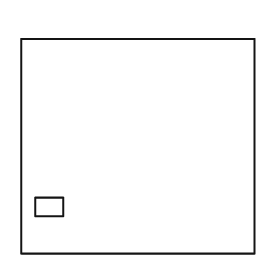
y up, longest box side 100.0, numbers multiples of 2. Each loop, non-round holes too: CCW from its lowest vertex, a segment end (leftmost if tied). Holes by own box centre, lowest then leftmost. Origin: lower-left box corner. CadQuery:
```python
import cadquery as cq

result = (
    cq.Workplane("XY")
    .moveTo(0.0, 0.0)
    .lineTo(100.0, 0.0)
    .lineTo(100.0, 92.0)
    .lineTo(0.0, 92.0)
    .close()
    .moveTo(6.0, 16.0)
    .lineTo(18.0, 16.0)
    .lineTo(18.0, 24.0)
    .lineTo(6.0, 24.0)
    .close()
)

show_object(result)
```